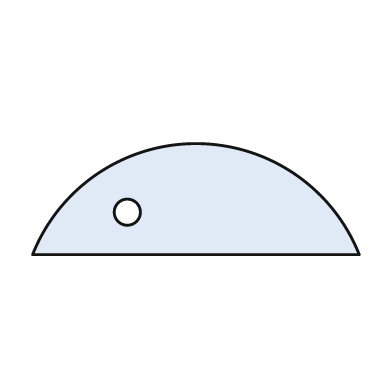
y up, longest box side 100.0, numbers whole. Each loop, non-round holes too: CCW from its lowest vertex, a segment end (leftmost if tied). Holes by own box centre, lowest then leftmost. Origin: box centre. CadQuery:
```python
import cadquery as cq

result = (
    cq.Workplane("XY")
    .moveTo(-50.0, -17.0)
    .lineTo(50.0, -17.0)
    .threePointArc((0.0, 17.0), (-50.0, -17.0))
    .close()
    .moveTo(-21.0, -4.0)
    .circle(4.0)
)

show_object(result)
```